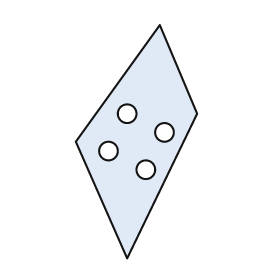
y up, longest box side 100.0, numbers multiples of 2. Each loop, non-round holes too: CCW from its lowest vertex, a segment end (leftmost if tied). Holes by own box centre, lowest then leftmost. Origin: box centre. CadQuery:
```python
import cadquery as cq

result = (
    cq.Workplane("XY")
    .moveTo(-4.0, -50.0)
    .lineTo(26.0, 12.0)
    .lineTo(10.0, 50.0)
    .lineTo(-26.0, 0.0)
    .close()
    .moveTo(4.0, -12.0)
    .circle(4.0)
    .moveTo(-12.0, -4.0)
    .circle(4.0)
    .moveTo(12.0, 4.0)
    .circle(4.0)
    .moveTo(-4.0, 12.0)
    .circle(4.0)
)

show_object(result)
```